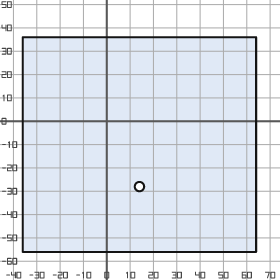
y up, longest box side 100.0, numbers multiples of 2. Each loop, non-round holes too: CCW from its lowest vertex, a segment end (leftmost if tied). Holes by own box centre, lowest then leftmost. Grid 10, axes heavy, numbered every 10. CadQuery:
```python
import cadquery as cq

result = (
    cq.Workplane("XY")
    .moveTo(-36.0, -56.0)
    .lineTo(64.0, -56.0)
    .lineTo(64.0, 36.0)
    .lineTo(-36.0, 36.0)
    .close()
    .moveTo(14.0, -28.0)
    .circle(2.0)
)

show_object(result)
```